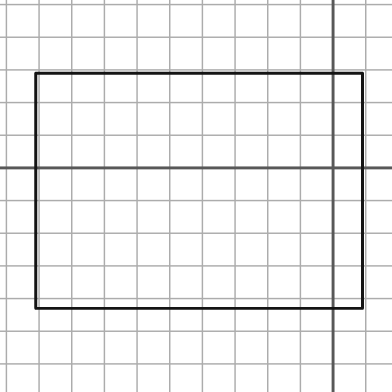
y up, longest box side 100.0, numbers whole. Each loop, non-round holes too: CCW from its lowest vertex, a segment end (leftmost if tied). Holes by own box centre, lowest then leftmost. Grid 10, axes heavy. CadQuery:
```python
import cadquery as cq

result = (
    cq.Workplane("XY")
    .moveTo(-91.0, -43.0)
    .lineTo(9.0, -43.0)
    .lineTo(9.0, 29.0)
    .lineTo(-91.0, 29.0)
    .close()
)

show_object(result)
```